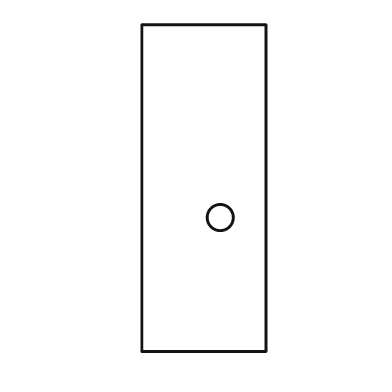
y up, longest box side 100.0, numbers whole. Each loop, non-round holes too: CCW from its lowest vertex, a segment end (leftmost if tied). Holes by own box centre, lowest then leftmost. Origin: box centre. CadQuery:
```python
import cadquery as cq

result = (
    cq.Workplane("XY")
    .moveTo(-19.0, -50.0)
    .lineTo(19.0, -50.0)
    .lineTo(19.0, 50.0)
    .lineTo(-19.0, 50.0)
    .close()
    .moveTo(5.0, -9.0)
    .circle(4.0)
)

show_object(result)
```